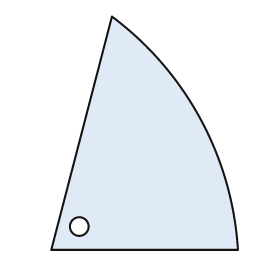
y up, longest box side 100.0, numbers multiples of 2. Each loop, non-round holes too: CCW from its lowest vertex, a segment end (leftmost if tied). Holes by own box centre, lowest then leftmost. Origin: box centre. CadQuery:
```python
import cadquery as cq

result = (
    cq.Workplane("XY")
    .moveTo(-40.0, -50.0)
    .lineTo(40.0, -50.0)
    .threePointArc((24.0, 6.0), (-14.0, 50.0))
    .close()
    .moveTo(-28.0, -40.0)
    .circle(4.0)
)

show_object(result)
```